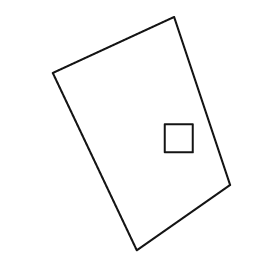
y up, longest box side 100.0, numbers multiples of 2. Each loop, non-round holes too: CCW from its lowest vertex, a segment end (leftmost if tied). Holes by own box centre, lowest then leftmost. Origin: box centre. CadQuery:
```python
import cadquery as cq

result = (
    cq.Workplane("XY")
    .moveTo(-2.0, -50.0)
    .lineTo(38.0, -22.0)
    .lineTo(14.0, 50.0)
    .lineTo(-38.0, 26.0)
    .close()
    .moveTo(10.0, -8.0)
    .lineTo(22.0, -8.0)
    .lineTo(22.0, 4.0)
    .lineTo(10.0, 4.0)
    .close()
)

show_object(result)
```